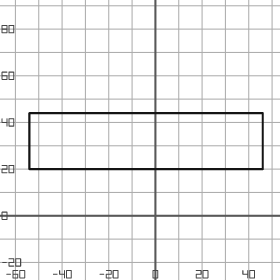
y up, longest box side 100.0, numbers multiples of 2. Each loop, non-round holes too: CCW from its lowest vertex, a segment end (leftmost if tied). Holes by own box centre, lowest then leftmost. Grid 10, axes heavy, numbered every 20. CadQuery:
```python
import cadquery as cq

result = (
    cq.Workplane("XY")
    .moveTo(-54.0, 20.0)
    .lineTo(46.0, 20.0)
    .lineTo(46.0, 44.0)
    .lineTo(-54.0, 44.0)
    .close()
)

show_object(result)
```